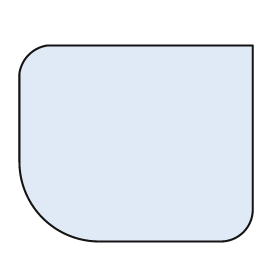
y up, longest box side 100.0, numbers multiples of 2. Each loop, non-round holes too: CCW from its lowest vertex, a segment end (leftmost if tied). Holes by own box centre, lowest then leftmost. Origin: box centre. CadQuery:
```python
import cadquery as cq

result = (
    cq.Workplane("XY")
    .moveTo(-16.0, -42.0)
    .lineTo(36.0, -42.0)
    .threePointArc((46.0, -38.0), (50.0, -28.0))
    .lineTo(50.0, 42.0)
    .lineTo(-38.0, 42.0)
    .threePointArc((-46.0, 38.0), (-50.0, 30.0))
    .lineTo(-50.0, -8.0)
    .threePointArc((-40.0, -32.0), (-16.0, -42.0))
    .close()
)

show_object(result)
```